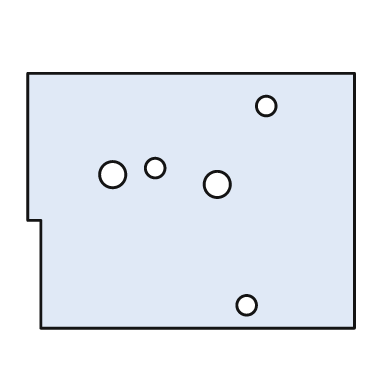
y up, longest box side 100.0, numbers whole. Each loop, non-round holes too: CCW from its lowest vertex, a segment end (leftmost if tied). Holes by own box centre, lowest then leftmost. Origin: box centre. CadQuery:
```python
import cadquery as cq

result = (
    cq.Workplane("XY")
    .moveTo(-46.0, -39.0)
    .lineTo(50.0, -39.0)
    .lineTo(50.0, 39.0)
    .lineTo(-50.0, 39.0)
    .lineTo(-50.0, -6.0)
    .lineTo(-46.0, -6.0)
    .close()
    .moveTo(17.0, -32.0)
    .circle(3.0)
    .moveTo(8.0, 5.0)
    .circle(4.0)
    .moveTo(-24.0, 8.0)
    .circle(4.0)
    .moveTo(-11.0, 10.0)
    .circle(3.0)
    .moveTo(23.0, 29.0)
    .circle(3.0)
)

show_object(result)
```